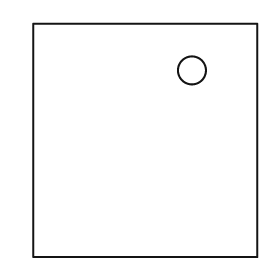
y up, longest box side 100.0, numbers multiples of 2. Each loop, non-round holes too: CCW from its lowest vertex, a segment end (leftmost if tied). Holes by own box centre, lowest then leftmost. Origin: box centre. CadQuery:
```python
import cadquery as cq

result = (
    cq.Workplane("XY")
    .moveTo(-48.0, -50.0)
    .lineTo(48.0, -50.0)
    .lineTo(48.0, 50.0)
    .lineTo(-48.0, 50.0)
    .close()
    .moveTo(20.0, 30.0)
    .circle(6.0)
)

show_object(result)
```